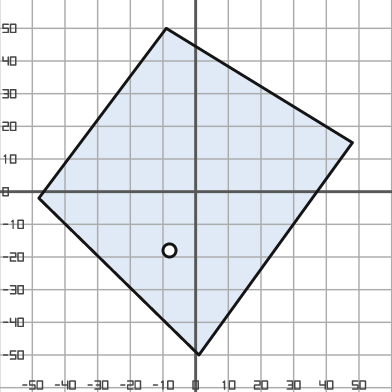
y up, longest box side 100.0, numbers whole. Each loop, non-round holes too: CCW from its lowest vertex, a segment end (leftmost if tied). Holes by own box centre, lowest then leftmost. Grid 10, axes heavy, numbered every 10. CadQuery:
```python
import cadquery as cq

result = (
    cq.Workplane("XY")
    .moveTo(1.0, -50.0)
    .lineTo(48.0, 15.0)
    .lineTo(-9.0, 50.0)
    .lineTo(-48.0, -2.0)
    .close()
    .moveTo(-8.0, -18.0)
    .circle(2.0)
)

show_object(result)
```